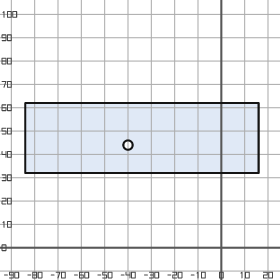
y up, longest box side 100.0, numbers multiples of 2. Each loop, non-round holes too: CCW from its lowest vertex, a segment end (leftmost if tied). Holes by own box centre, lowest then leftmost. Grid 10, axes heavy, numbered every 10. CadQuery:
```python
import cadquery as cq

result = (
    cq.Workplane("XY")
    .moveTo(-84.0, 32.0)
    .lineTo(16.0, 32.0)
    .lineTo(16.0, 62.0)
    .lineTo(-84.0, 62.0)
    .close()
    .moveTo(-40.0, 44.0)
    .circle(2.0)
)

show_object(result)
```